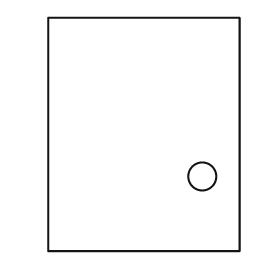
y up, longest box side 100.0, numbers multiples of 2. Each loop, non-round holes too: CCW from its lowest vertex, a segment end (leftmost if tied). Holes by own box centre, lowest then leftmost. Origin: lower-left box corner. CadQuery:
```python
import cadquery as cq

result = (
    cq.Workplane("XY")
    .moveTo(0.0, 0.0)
    .lineTo(82.0, 0.0)
    .lineTo(82.0, 100.0)
    .lineTo(0.0, 100.0)
    .close()
    .moveTo(66.0, 32.0)
    .circle(6.0)
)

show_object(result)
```